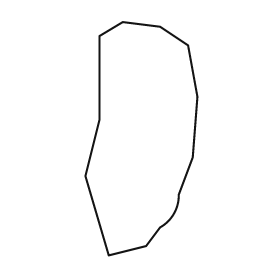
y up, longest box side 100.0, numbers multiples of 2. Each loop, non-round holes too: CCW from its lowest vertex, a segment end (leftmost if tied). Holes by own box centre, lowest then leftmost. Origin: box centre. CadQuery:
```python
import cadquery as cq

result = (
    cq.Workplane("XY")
    .moveTo(-14.0, -50.0)
    .lineTo(2.0, -46.0)
    .lineTo(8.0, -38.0)
    .threePointArc((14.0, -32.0), (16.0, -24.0))
    .lineTo(22.0, -8.0)
    .lineTo(24.0, 18.0)
    .lineTo(20.0, 40.0)
    .lineTo(8.0, 48.0)
    .lineTo(-8.0, 50.0)
    .lineTo(-18.0, 44.0)
    .lineTo(-18.0, 8.0)
    .lineTo(-24.0, -16.0)
    .close()
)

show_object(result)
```